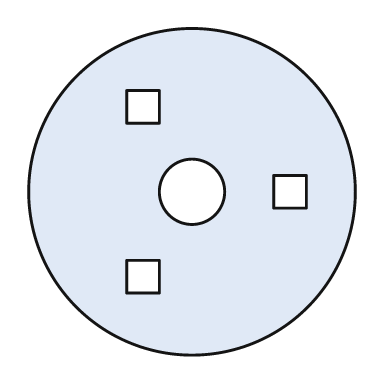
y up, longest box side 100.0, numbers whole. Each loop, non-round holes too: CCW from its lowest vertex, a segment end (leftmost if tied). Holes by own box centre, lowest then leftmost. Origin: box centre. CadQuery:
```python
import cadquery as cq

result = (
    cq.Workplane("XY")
    .moveTo(0.0, 0.0)
    .circle(50.0)
    .moveTo(-20.0, -31.0)
    .lineTo(-10.0, -31.0)
    .lineTo(-10.0, -21.0)
    .lineTo(-20.0, -21.0)
    .close()
    .moveTo(0.0, 0.0)
    .circle(10.0)
    .moveTo(25.0, -5.0)
    .lineTo(35.0, -5.0)
    .lineTo(35.0, 5.0)
    .lineTo(25.0, 5.0)
    .close()
    .moveTo(-20.0, 21.0)
    .lineTo(-10.0, 21.0)
    .lineTo(-10.0, 31.0)
    .lineTo(-20.0, 31.0)
    .close()
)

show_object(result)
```